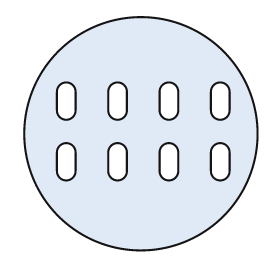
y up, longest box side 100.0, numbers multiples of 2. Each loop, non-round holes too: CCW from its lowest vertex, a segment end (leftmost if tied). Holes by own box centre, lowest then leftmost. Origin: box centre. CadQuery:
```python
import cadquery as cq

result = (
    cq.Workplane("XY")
    .moveTo(0.0, 0.0)
    .circle(50.0)
    .moveTo(-36.0, -16.0)
    .threePointArc((-32.0, -20.0), (-28.0, -16.0))
    .lineTo(-28.0, -8.0)
    .threePointArc((-32.0, -4.0), (-36.0, -8.0))
    .close()
    .moveTo(-14.0, -16.0)
    .threePointArc((-10.0, -20.0), (-6.0, -16.0))
    .lineTo(-6.0, -8.0)
    .threePointArc((-10.0, -4.0), (-14.0, -8.0))
    .close()
    .moveTo(8.0, -16.0)
    .threePointArc((12.0, -20.0), (16.0, -16.0))
    .lineTo(16.0, -8.0)
    .threePointArc((12.0, -4.0), (8.0, -8.0))
    .close()
    .moveTo(30.0, -16.0)
    .threePointArc((34.0, -20.0), (38.0, -16.0))
    .lineTo(38.0, -8.0)
    .threePointArc((34.0, -4.0), (30.0, -8.0))
    .close()
    .moveTo(-36.0, 10.0)
    .threePointArc((-32.0, 6.0), (-28.0, 10.0))
    .lineTo(-28.0, 18.0)
    .threePointArc((-32.0, 22.0), (-36.0, 18.0))
    .close()
    .moveTo(-14.0, 10.0)
    .threePointArc((-10.0, 6.0), (-6.0, 10.0))
    .lineTo(-6.0, 18.0)
    .threePointArc((-10.0, 22.0), (-14.0, 18.0))
    .close()
    .moveTo(8.0, 10.0)
    .threePointArc((12.0, 6.0), (16.0, 10.0))
    .lineTo(16.0, 18.0)
    .threePointArc((12.0, 22.0), (8.0, 18.0))
    .close()
    .moveTo(30.0, 10.0)
    .threePointArc((34.0, 6.0), (38.0, 10.0))
    .lineTo(38.0, 18.0)
    .threePointArc((34.0, 22.0), (30.0, 18.0))
    .close()
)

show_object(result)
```